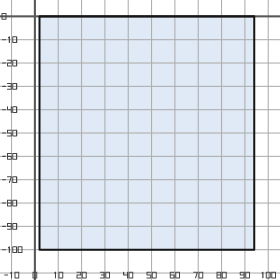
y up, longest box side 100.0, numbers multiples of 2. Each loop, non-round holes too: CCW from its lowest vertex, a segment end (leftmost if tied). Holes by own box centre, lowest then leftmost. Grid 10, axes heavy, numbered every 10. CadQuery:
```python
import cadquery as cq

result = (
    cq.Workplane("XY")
    .moveTo(2.0, -100.0)
    .lineTo(94.0, -100.0)
    .lineTo(94.0, 0.0)
    .lineTo(2.0, 0.0)
    .close()
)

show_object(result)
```